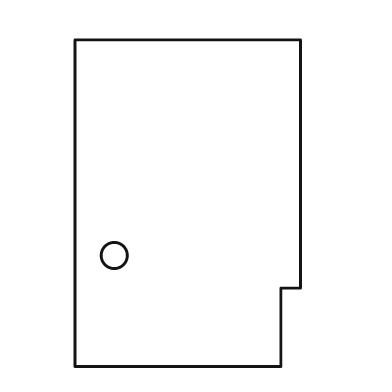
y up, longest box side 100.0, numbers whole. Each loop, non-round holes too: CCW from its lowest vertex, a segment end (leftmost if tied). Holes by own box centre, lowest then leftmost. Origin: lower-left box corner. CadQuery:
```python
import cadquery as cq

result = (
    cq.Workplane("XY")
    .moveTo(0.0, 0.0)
    .lineTo(63.0, 0.0)
    .lineTo(63.0, 24.0)
    .lineTo(69.0, 24.0)
    .lineTo(69.0, 100.0)
    .lineTo(0.0, 100.0)
    .close()
    .moveTo(12.0, 34.0)
    .circle(4.0)
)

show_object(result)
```